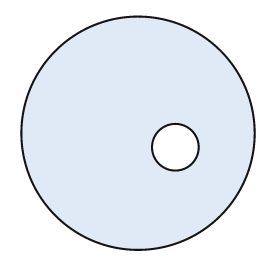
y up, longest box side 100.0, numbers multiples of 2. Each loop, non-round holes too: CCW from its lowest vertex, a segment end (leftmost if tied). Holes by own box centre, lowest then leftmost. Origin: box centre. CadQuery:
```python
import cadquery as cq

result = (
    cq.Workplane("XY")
    .moveTo(0.0, 0.0)
    .circle(50.0)
    .moveTo(16.0, -6.0)
    .circle(10.0)
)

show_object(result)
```